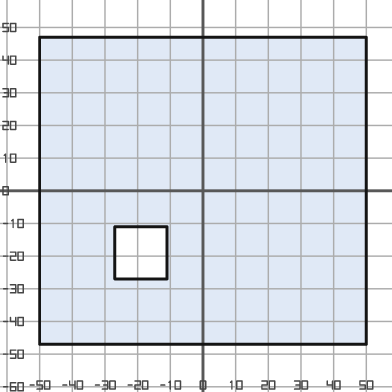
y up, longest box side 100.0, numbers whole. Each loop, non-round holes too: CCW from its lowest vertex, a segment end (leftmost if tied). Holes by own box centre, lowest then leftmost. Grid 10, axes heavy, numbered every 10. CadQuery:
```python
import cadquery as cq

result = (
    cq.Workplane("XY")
    .moveTo(-50.0, -47.0)
    .lineTo(50.0, -47.0)
    .lineTo(50.0, 47.0)
    .lineTo(-50.0, 47.0)
    .close()
    .moveTo(-27.0, -27.0)
    .lineTo(-11.0, -27.0)
    .lineTo(-11.0, -11.0)
    .lineTo(-27.0, -11.0)
    .close()
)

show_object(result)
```